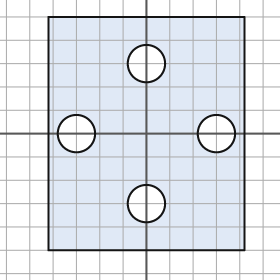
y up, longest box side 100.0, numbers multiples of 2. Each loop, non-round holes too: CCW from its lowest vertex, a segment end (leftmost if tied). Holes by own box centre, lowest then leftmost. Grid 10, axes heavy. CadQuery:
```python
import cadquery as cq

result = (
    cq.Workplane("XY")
    .moveTo(-42.0, -50.0)
    .lineTo(42.0, -50.0)
    .lineTo(42.0, 50.0)
    .lineTo(-42.0, 50.0)
    .close()
    .moveTo(0.0, -30.0)
    .circle(8.0)
    .moveTo(-30.0, 0.0)
    .circle(8.0)
    .moveTo(30.0, 0.0)
    .circle(8.0)
    .moveTo(0.0, 30.0)
    .circle(8.0)
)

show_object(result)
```